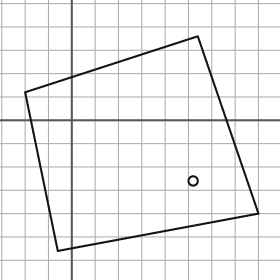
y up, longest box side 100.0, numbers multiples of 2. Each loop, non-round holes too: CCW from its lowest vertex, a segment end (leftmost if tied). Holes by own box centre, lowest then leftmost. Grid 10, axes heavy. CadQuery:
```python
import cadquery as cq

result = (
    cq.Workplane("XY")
    .moveTo(-6.0, -56.0)
    .lineTo(80.0, -40.0)
    .lineTo(54.0, 36.0)
    .lineTo(-20.0, 12.0)
    .close()
    .moveTo(52.0, -26.0)
    .circle(2.0)
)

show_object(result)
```